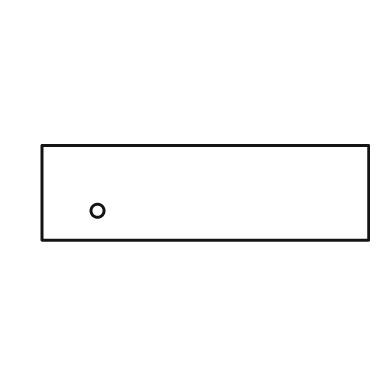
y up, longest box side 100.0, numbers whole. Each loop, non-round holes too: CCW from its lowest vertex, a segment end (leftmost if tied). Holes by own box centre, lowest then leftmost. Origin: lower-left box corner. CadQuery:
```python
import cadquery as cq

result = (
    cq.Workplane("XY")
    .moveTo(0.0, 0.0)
    .lineTo(100.0, 0.0)
    .lineTo(100.0, 29.0)
    .lineTo(0.0, 29.0)
    .close()
    .moveTo(17.0, 9.0)
    .circle(2.0)
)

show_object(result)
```